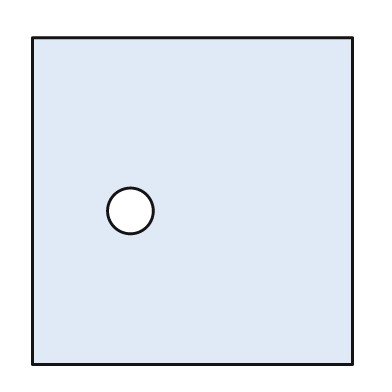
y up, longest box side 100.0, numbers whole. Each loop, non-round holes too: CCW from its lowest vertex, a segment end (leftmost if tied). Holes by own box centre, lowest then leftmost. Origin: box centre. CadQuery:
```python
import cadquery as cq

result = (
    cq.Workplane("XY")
    .moveTo(-49.0, -50.0)
    .lineTo(49.0, -50.0)
    .lineTo(49.0, 50.0)
    .lineTo(-49.0, 50.0)
    .close()
    .moveTo(-19.0, -3.0)
    .circle(7.0)
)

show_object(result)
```